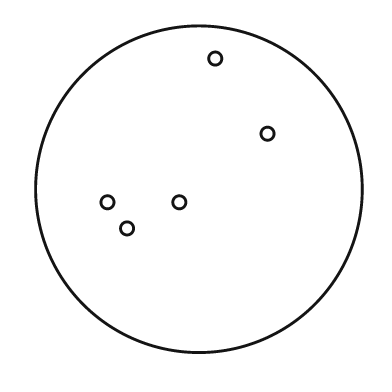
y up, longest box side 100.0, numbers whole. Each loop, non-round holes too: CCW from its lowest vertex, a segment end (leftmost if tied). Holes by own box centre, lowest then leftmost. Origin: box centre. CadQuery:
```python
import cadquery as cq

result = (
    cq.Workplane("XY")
    .moveTo(0.0, 0.0)
    .circle(50.0)
    .moveTo(-22.0, -12.0)
    .circle(2.0)
    .moveTo(-28.0, -4.0)
    .circle(2.0)
    .moveTo(-6.0, -4.0)
    .circle(2.0)
    .moveTo(21.0, 17.0)
    .circle(2.0)
    .moveTo(5.0, 40.0)
    .circle(2.0)
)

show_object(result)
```